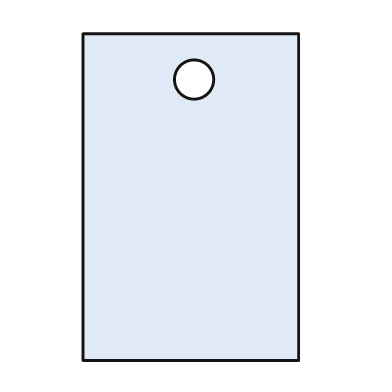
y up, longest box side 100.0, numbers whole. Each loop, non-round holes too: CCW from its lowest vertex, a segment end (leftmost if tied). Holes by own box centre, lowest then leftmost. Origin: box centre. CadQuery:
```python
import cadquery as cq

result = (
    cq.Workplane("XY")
    .moveTo(-33.0, -50.0)
    .lineTo(33.0, -50.0)
    .lineTo(33.0, 50.0)
    .lineTo(-33.0, 50.0)
    .close()
    .moveTo(1.0, 36.0)
    .circle(6.0)
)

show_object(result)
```